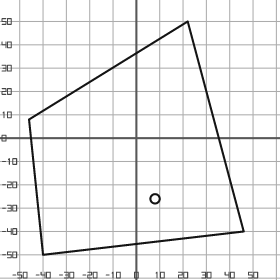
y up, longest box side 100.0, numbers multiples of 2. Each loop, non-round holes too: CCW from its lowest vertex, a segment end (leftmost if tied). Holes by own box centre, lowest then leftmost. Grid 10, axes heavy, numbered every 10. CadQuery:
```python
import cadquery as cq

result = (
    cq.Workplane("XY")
    .moveTo(-40.0, -50.0)
    .lineTo(46.0, -40.0)
    .lineTo(22.0, 50.0)
    .lineTo(-46.0, 8.0)
    .close()
    .moveTo(8.0, -26.0)
    .circle(2.0)
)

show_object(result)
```